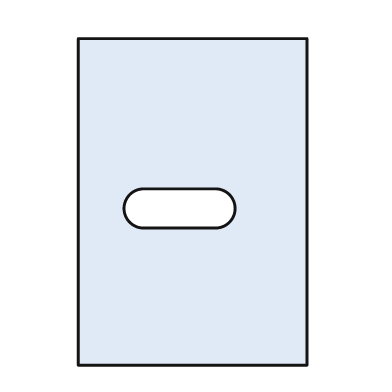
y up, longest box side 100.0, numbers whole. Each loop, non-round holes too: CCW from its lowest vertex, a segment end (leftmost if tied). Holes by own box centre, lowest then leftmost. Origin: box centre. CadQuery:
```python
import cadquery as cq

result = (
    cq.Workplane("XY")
    .moveTo(-35.0, -50.0)
    .lineTo(35.0, -50.0)
    .lineTo(35.0, 50.0)
    .lineTo(-35.0, 50.0)
    .close()
    .moveTo(-15.0, -8.0)
    .lineTo(7.0, -8.0)
    .threePointArc((13.0, -2.0), (7.0, 4.0))
    .lineTo(-15.0, 4.0)
    .threePointArc((-21.0, -2.0), (-15.0, -8.0))
    .close()
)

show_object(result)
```